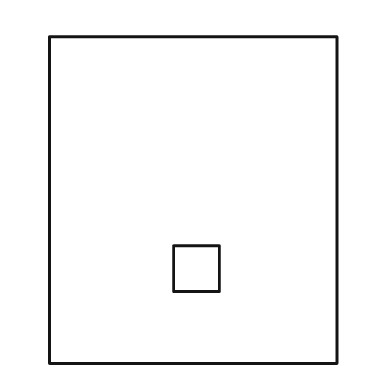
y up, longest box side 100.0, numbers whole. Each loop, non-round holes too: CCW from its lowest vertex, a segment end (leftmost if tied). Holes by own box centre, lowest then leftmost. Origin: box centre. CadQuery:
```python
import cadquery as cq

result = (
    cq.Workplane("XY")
    .moveTo(-44.0, -50.0)
    .lineTo(44.0, -50.0)
    .lineTo(44.0, 50.0)
    .lineTo(-44.0, 50.0)
    .close()
    .moveTo(-6.0, -28.0)
    .lineTo(8.0, -28.0)
    .lineTo(8.0, -14.0)
    .lineTo(-6.0, -14.0)
    .close()
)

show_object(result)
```